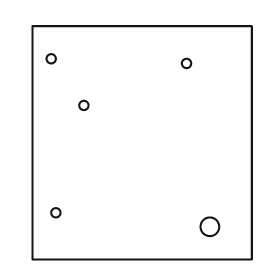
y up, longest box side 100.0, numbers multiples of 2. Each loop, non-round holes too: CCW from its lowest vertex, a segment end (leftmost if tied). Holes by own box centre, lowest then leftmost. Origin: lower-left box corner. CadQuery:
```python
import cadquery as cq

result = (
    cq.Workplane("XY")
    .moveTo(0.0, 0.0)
    .lineTo(94.0, 0.0)
    .lineTo(94.0, 100.0)
    .lineTo(0.0, 100.0)
    .close()
    .moveTo(76.0, 14.0)
    .circle(4.0)
    .moveTo(10.0, 20.0)
    .circle(2.0)
    .moveTo(22.0, 66.0)
    .circle(2.0)
    .moveTo(66.0, 84.0)
    .circle(2.0)
    .moveTo(8.0, 86.0)
    .circle(2.0)
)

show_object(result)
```